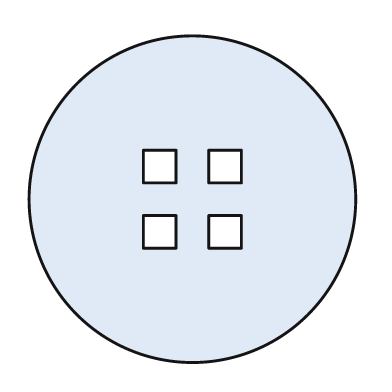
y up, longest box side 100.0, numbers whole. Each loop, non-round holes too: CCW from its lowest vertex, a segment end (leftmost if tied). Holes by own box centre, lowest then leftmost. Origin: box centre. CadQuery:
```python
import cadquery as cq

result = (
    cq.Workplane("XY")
    .moveTo(0.0, 0.0)
    .circle(50.0)
    .moveTo(-15.0, -15.0)
    .lineTo(-5.0, -15.0)
    .lineTo(-5.0, -5.0)
    .lineTo(-15.0, -5.0)
    .close()
    .moveTo(5.0, -15.0)
    .lineTo(15.0, -15.0)
    .lineTo(15.0, -5.0)
    .lineTo(5.0, -5.0)
    .close()
    .moveTo(-15.0, 5.0)
    .lineTo(-5.0, 5.0)
    .lineTo(-5.0, 15.0)
    .lineTo(-15.0, 15.0)
    .close()
    .moveTo(5.0, 5.0)
    .lineTo(15.0, 5.0)
    .lineTo(15.0, 15.0)
    .lineTo(5.0, 15.0)
    .close()
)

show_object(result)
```